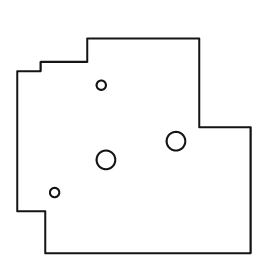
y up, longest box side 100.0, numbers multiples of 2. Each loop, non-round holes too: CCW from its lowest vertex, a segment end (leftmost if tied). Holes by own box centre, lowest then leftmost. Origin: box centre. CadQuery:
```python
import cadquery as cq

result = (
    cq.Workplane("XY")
    .moveTo(-38.0, -46.0)
    .lineTo(50.0, -46.0)
    .lineTo(50.0, 8.0)
    .lineTo(28.0, 8.0)
    .lineTo(28.0, 46.0)
    .lineTo(-20.0, 46.0)
    .lineTo(-20.0, 36.0)
    .lineTo(-40.0, 36.0)
    .lineTo(-40.0, 32.0)
    .lineTo(-50.0, 32.0)
    .lineTo(-50.0, -28.0)
    .lineTo(-38.0, -28.0)
    .close()
    .moveTo(-34.0, -20.0)
    .circle(2.0)
    .moveTo(-12.0, -6.0)
    .circle(4.0)
    .moveTo(18.0, 2.0)
    .circle(4.0)
    .moveTo(-14.0, 26.0)
    .circle(2.0)
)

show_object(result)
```